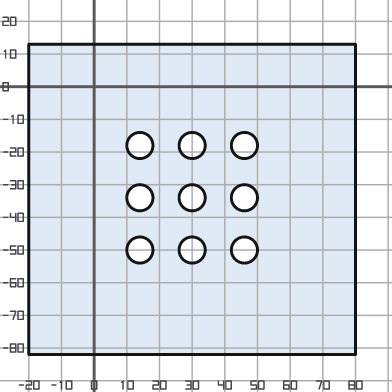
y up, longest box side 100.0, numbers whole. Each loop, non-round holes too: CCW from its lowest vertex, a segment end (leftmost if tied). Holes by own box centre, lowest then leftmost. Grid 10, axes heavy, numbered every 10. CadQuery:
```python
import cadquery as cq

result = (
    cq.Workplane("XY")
    .moveTo(-20.0, -82.0)
    .lineTo(80.0, -82.0)
    .lineTo(80.0, 13.0)
    .lineTo(-20.0, 13.0)
    .close()
    .moveTo(14.0, -50.0)
    .circle(4.0)
    .moveTo(30.0, -50.0)
    .circle(4.0)
    .moveTo(46.0, -50.0)
    .circle(4.0)
    .moveTo(14.0, -34.0)
    .circle(4.0)
    .moveTo(30.0, -34.0)
    .circle(4.0)
    .moveTo(46.0, -34.0)
    .circle(4.0)
    .moveTo(14.0, -18.0)
    .circle(4.0)
    .moveTo(30.0, -18.0)
    .circle(4.0)
    .moveTo(46.0, -18.0)
    .circle(4.0)
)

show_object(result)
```